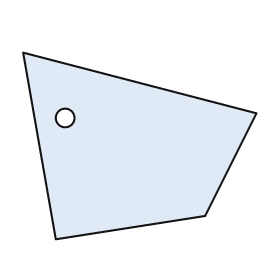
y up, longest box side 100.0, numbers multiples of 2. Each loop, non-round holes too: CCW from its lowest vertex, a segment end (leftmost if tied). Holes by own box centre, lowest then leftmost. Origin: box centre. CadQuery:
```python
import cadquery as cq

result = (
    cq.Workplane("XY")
    .moveTo(-36.0, -40.0)
    .lineTo(28.0, -30.0)
    .lineTo(50.0, 14.0)
    .lineTo(-50.0, 40.0)
    .close()
    .moveTo(-32.0, 12.0)
    .circle(4.0)
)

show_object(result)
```